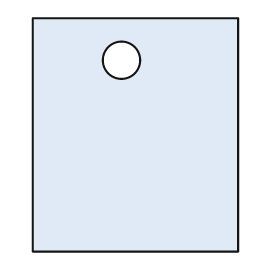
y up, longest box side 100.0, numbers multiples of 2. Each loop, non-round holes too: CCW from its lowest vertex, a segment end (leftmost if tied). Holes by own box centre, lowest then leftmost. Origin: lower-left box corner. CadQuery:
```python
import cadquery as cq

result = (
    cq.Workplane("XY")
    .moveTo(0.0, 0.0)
    .lineTo(88.0, 0.0)
    .lineTo(88.0, 100.0)
    .lineTo(0.0, 100.0)
    .close()
    .moveTo(38.0, 82.0)
    .circle(8.0)
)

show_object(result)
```